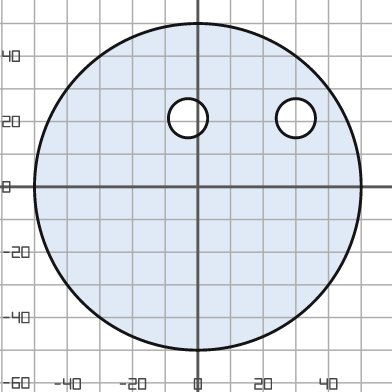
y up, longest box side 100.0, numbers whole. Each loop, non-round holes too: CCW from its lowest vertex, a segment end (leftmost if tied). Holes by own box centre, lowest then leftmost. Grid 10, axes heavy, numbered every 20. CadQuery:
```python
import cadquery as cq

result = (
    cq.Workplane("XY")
    .moveTo(0.0, 0.0)
    .circle(50.0)
    .moveTo(-3.0, 21.0)
    .circle(6.0)
    .moveTo(30.0, 21.0)
    .circle(6.0)
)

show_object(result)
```